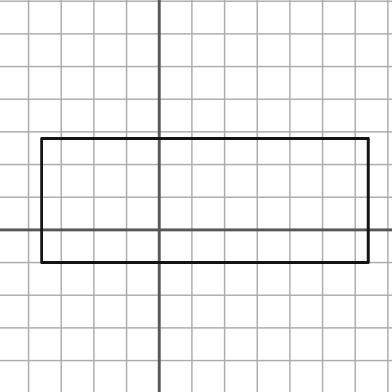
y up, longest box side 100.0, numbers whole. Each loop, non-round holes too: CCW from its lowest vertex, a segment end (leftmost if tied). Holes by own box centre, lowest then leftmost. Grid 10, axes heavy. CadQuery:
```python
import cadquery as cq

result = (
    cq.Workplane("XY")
    .moveTo(-36.0, -10.0)
    .lineTo(64.0, -10.0)
    .lineTo(64.0, 28.0)
    .lineTo(-36.0, 28.0)
    .close()
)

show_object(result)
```